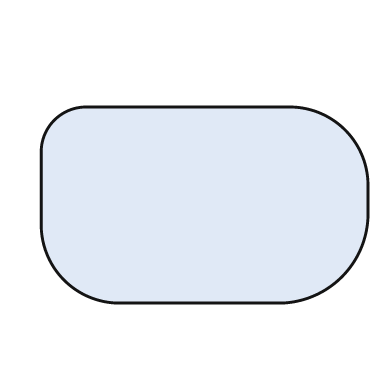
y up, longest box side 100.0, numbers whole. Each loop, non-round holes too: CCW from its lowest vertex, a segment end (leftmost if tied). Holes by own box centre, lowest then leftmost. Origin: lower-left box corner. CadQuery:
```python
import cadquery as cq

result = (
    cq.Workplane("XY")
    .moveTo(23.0, 0.0)
    .lineTo(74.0, 0.0)
    .threePointArc((92.0, 8.0), (100.0, 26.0))
    .lineTo(100.0, 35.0)
    .threePointArc((93.0, 53.0), (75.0, 60.0))
    .lineTo(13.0, 60.0)
    .threePointArc((4.0, 56.0), (0.0, 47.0))
    .lineTo(0.0, 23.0)
    .threePointArc((7.0, 7.0), (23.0, 0.0))
    .close()
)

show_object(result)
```